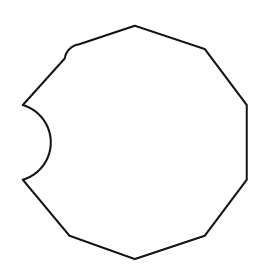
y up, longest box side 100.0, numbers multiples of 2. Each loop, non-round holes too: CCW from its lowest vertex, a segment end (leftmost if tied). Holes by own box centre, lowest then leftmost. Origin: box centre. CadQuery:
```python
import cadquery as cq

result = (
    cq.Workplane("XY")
    .moveTo(0.0, -50.0)
    .lineTo(30.0, -40.0)
    .lineTo(48.0, -16.0)
    .lineTo(48.0, 16.0)
    .lineTo(30.0, 40.0)
    .lineTo(0.0, 50.0)
    .lineTo(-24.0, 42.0)
    .threePointArc((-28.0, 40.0), (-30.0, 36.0))
    .lineTo(-48.0, 16.0)
    .threePointArc((-36.0, 0.0), (-48.0, -16.0))
    .lineTo(-28.0, -40.0)
    .close()
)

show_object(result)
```